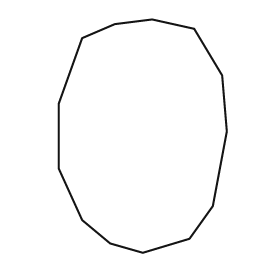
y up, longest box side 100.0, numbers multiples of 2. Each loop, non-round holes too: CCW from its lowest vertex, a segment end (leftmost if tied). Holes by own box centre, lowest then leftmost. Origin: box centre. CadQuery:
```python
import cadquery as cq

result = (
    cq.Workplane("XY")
    .moveTo(0.0, -50.0)
    .lineTo(20.0, -44.0)
    .lineTo(30.0, -30.0)
    .lineTo(36.0, 2.0)
    .lineTo(34.0, 26.0)
    .lineTo(22.0, 46.0)
    .lineTo(4.0, 50.0)
    .lineTo(-12.0, 48.0)
    .lineTo(-26.0, 42.0)
    .lineTo(-36.0, 14.0)
    .lineTo(-36.0, -14.0)
    .lineTo(-26.0, -36.0)
    .lineTo(-14.0, -46.0)
    .close()
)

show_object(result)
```